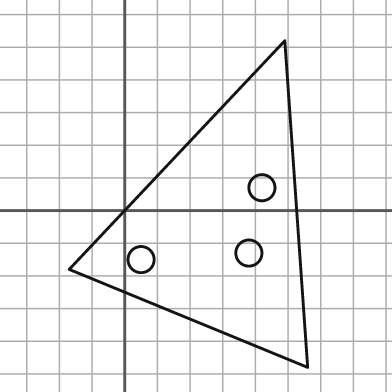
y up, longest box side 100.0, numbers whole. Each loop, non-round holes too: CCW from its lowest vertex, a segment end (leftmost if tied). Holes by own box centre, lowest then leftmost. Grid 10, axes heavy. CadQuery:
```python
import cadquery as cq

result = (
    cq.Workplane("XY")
    .moveTo(56.0, -48.0)
    .lineTo(49.0, 52.0)
    .lineTo(-17.0, -18.0)
    .close()
    .moveTo(5.0, -15.0)
    .circle(4.0)
    .moveTo(38.0, -13.0)
    .circle(4.0)
    .moveTo(42.0, 7.0)
    .circle(4.0)
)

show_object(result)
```